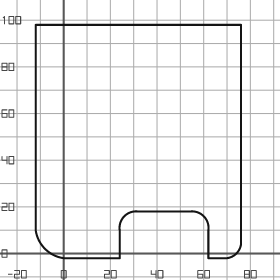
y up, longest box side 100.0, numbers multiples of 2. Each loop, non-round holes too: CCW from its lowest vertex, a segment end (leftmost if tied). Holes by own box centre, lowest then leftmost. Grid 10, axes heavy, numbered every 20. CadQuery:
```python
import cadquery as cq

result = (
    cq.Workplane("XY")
    .moveTo(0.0, -2.0)
    .lineTo(24.0, -2.0)
    .lineTo(24.0, 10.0)
    .threePointArc((26.0, 16.0), (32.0, 18.0))
    .lineTo(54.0, 18.0)
    .threePointArc((60.0, 16.0), (62.0, 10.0))
    .lineTo(62.0, -2.0)
    .lineTo(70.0, -2.0)
    .threePointArc((74.0, 0.0), (76.0, 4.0))
    .lineTo(76.0, 98.0)
    .lineTo(-12.0, 98.0)
    .lineTo(-12.0, 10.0)
    .threePointArc((-8.0, 2.0), (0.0, -2.0))
    .close()
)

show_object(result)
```